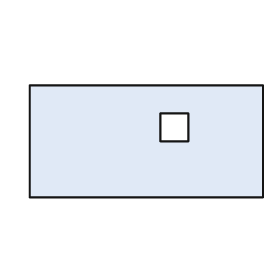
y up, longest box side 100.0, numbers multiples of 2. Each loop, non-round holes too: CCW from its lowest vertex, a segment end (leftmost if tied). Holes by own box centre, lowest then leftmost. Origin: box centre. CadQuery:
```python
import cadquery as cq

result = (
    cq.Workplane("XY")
    .moveTo(-50.0, -24.0)
    .lineTo(50.0, -24.0)
    .lineTo(50.0, 24.0)
    .lineTo(-50.0, 24.0)
    .close()
    .moveTo(6.0, 0.0)
    .lineTo(18.0, 0.0)
    .lineTo(18.0, 12.0)
    .lineTo(6.0, 12.0)
    .close()
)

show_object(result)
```